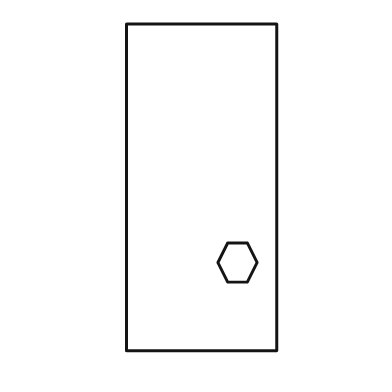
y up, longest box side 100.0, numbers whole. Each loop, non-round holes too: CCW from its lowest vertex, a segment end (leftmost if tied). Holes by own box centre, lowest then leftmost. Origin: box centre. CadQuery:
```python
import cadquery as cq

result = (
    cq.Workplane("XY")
    .moveTo(-23.0, -50.0)
    .lineTo(23.0, -50.0)
    .lineTo(23.0, 50.0)
    .lineTo(-23.0, 50.0)
    .close()
    .moveTo(8.0, -29.0)
    .lineTo(14.0, -29.0)
    .lineTo(17.0, -23.0)
    .lineTo(14.0, -17.0)
    .lineTo(8.0, -17.0)
    .lineTo(5.0, -23.0)
    .close()
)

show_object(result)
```